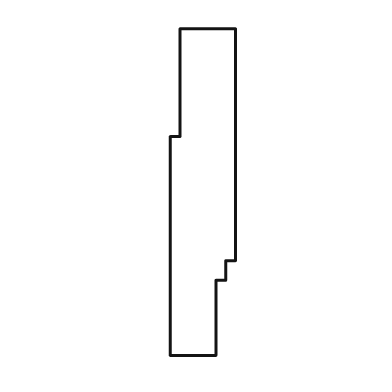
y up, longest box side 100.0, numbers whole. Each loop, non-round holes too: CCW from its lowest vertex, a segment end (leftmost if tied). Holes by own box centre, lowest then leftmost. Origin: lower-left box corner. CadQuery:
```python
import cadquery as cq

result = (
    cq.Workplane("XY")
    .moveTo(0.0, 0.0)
    .lineTo(14.0, 0.0)
    .lineTo(14.0, 23.0)
    .lineTo(17.0, 23.0)
    .lineTo(17.0, 29.0)
    .lineTo(20.0, 29.0)
    .lineTo(20.0, 100.0)
    .lineTo(3.0, 100.0)
    .lineTo(3.0, 67.0)
    .lineTo(0.0, 67.0)
    .close()
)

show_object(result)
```